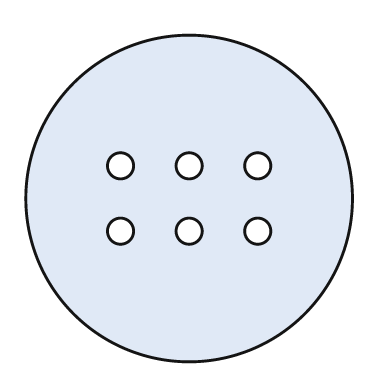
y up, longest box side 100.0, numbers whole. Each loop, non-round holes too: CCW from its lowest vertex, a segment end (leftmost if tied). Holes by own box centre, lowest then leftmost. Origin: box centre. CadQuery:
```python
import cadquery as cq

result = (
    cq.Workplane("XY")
    .moveTo(0.0, 0.0)
    .circle(50.0)
    .moveTo(-21.0, -10.0)
    .circle(4.0)
    .moveTo(0.0, -10.0)
    .circle(4.0)
    .moveTo(21.0, -10.0)
    .circle(4.0)
    .moveTo(-21.0, 10.0)
    .circle(4.0)
    .moveTo(0.0, 10.0)
    .circle(4.0)
    .moveTo(21.0, 10.0)
    .circle(4.0)
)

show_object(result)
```